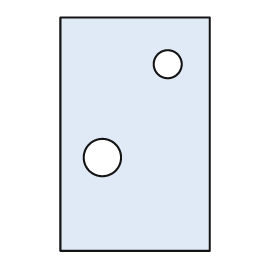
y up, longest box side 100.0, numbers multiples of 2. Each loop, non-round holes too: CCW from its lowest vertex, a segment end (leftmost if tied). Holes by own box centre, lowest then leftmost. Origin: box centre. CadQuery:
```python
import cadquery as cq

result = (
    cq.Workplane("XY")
    .moveTo(-32.0, -50.0)
    .lineTo(32.0, -50.0)
    .lineTo(32.0, 50.0)
    .lineTo(-32.0, 50.0)
    .close()
    .moveTo(-14.0, -10.0)
    .circle(8.0)
    .moveTo(14.0, 30.0)
    .circle(6.0)
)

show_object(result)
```